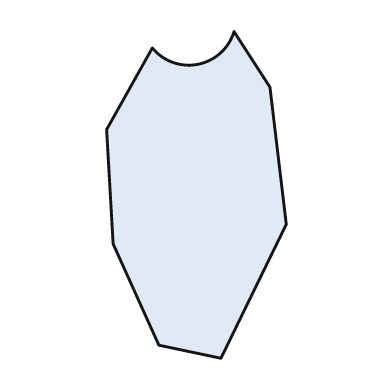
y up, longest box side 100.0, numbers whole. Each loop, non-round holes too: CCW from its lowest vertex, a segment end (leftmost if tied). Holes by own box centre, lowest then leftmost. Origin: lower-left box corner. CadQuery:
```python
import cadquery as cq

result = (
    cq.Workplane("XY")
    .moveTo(35.0, 0.0)
    .lineTo(55.0, 41.0)
    .lineTo(50.0, 83.0)
    .lineTo(39.0, 100.0)
    .threePointArc((28.0, 90.0), (14.0, 95.0))
    .lineTo(0.0, 70.0)
    .lineTo(2.0, 35.0)
    .lineTo(16.0, 4.0)
    .close()
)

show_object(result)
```